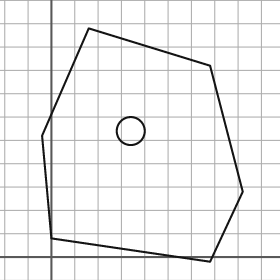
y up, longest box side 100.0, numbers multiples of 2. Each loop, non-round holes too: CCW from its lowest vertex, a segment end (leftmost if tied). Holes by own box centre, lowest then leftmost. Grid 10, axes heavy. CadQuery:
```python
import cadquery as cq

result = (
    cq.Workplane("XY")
    .moveTo(68.0, -2.0)
    .lineTo(82.0, 28.0)
    .lineTo(68.0, 82.0)
    .lineTo(16.0, 98.0)
    .lineTo(-4.0, 52.0)
    .lineTo(0.0, 8.0)
    .close()
    .moveTo(34.0, 54.0)
    .circle(6.0)
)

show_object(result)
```